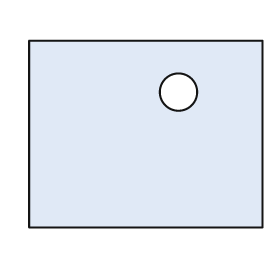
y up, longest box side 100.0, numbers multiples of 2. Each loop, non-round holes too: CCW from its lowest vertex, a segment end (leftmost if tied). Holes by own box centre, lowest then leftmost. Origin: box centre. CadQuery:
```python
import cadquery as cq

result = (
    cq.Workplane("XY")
    .moveTo(-50.0, -40.0)
    .lineTo(50.0, -40.0)
    .lineTo(50.0, 40.0)
    .lineTo(-50.0, 40.0)
    .close()
    .moveTo(14.0, 18.0)
    .circle(8.0)
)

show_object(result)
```